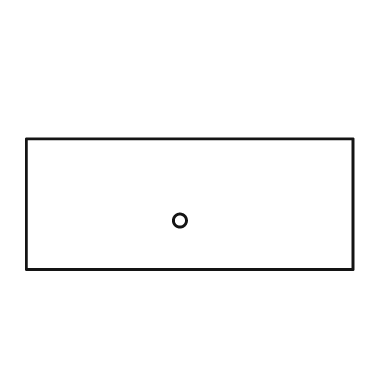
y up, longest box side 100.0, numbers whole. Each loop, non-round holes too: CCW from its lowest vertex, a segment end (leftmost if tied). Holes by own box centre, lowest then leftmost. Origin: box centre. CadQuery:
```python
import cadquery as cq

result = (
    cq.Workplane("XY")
    .moveTo(-50.0, -20.0)
    .lineTo(50.0, -20.0)
    .lineTo(50.0, 20.0)
    .lineTo(-50.0, 20.0)
    .close()
    .moveTo(-3.0, -5.0)
    .circle(2.0)
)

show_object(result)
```